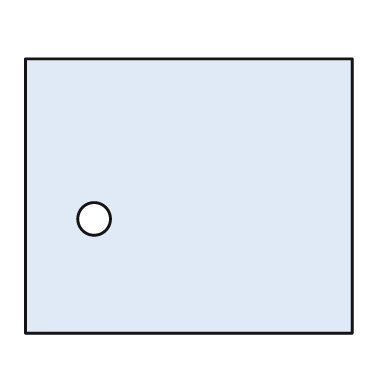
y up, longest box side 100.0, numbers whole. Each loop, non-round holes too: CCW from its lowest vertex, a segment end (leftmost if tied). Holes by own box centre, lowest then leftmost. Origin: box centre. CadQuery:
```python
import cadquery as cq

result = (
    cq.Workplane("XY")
    .moveTo(-50.0, -42.0)
    .lineTo(50.0, -42.0)
    .lineTo(50.0, 42.0)
    .lineTo(-50.0, 42.0)
    .close()
    .moveTo(-29.0, -7.0)
    .circle(5.0)
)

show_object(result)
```